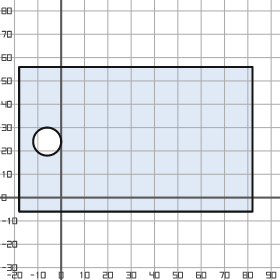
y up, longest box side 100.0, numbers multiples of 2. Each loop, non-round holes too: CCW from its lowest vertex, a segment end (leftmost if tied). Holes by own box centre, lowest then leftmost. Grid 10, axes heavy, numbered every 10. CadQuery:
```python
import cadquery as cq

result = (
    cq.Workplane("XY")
    .moveTo(-18.0, -6.0)
    .lineTo(82.0, -6.0)
    .lineTo(82.0, 56.0)
    .lineTo(-18.0, 56.0)
    .close()
    .moveTo(-6.0, 24.0)
    .circle(6.0)
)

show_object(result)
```